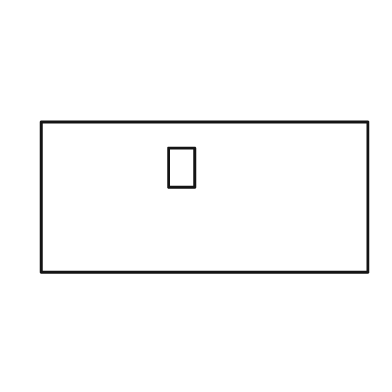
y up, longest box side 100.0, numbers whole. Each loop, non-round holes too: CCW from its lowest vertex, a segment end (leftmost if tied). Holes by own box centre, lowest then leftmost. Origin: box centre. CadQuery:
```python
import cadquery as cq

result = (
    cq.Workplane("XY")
    .moveTo(-50.0, -23.0)
    .lineTo(50.0, -23.0)
    .lineTo(50.0, 23.0)
    .lineTo(-50.0, 23.0)
    .close()
    .moveTo(-11.0, 3.0)
    .lineTo(-3.0, 3.0)
    .lineTo(-3.0, 15.0)
    .lineTo(-11.0, 15.0)
    .close()
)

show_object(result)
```